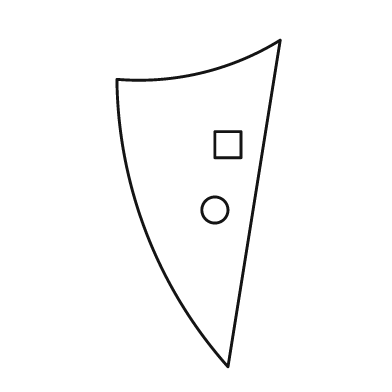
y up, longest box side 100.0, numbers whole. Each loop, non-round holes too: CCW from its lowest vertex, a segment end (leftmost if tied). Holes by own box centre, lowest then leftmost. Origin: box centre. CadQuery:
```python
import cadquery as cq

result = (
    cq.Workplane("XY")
    .moveTo(9.0, -50.0)
    .lineTo(25.0, 50.0)
    .threePointArc((1.0, 40.0), (-25.0, 38.0))
    .threePointArc((-16.0, -9.0), (9.0, -50.0))
    .close()
    .moveTo(5.0, -2.0)
    .circle(4.0)
    .moveTo(5.0, 14.0)
    .lineTo(13.0, 14.0)
    .lineTo(13.0, 22.0)
    .lineTo(5.0, 22.0)
    .close()
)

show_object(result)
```